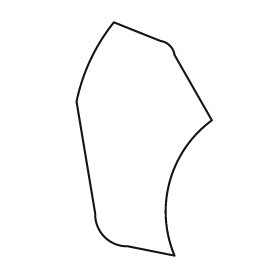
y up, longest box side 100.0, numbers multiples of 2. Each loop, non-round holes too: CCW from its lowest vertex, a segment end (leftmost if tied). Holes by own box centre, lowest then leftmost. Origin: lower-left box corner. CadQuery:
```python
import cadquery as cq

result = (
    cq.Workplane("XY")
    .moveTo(42.0, 0.0)
    .threePointArc((40.0, 32.0), (58.0, 58.0))
    .lineTo(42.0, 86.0)
    .threePointArc((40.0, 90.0), (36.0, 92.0))
    .lineTo(16.0, 100.0)
    .threePointArc((6.0, 84.0), (0.0, 66.0))
    .lineTo(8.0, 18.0)
    .threePointArc((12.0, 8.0), (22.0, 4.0))
    .close()
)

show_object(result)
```